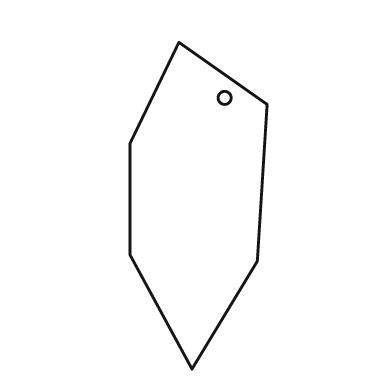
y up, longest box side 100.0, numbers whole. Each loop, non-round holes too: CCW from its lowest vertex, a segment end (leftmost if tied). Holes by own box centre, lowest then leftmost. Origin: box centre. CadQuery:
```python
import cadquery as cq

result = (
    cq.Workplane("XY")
    .moveTo(-2.0, -50.0)
    .lineTo(18.0, -17.0)
    .lineTo(21.0, 31.0)
    .lineTo(-6.0, 50.0)
    .lineTo(-21.0, 19.0)
    .lineTo(-21.0, -15.0)
    .close()
    .moveTo(8.0, 33.0)
    .circle(2.0)
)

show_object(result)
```